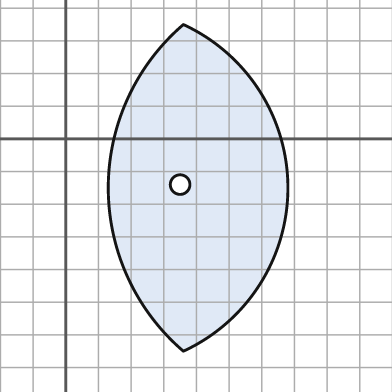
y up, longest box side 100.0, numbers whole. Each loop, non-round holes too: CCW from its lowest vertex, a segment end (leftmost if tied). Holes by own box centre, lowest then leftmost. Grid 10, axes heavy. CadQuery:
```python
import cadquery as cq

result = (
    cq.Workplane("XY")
    .moveTo(36.0, -65.0)
    .threePointArc((68.0, -15.0), (36.0, 35.0))
    .threePointArc((13.0, -15.0), (36.0, -65.0))
    .close()
    .moveTo(35.0, -14.0)
    .circle(3.0)
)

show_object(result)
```